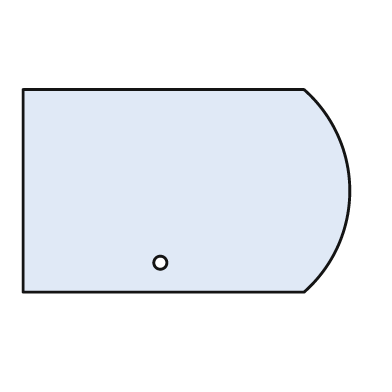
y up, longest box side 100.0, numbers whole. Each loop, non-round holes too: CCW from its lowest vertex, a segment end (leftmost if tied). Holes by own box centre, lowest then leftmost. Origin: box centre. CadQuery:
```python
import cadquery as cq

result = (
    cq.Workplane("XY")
    .moveTo(-50.0, -31.0)
    .lineTo(36.0, -31.0)
    .threePointArc((50.0, 0.0), (36.0, 31.0))
    .lineTo(-50.0, 31.0)
    .close()
    .moveTo(-8.0, -22.0)
    .circle(2.0)
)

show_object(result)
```